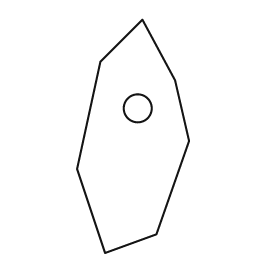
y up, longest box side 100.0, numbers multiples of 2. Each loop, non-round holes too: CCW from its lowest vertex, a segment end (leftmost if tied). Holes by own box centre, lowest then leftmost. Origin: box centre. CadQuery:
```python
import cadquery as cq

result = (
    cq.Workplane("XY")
    .moveTo(-12.0, -50.0)
    .lineTo(10.0, -42.0)
    .lineTo(24.0, -2.0)
    .lineTo(18.0, 24.0)
    .lineTo(4.0, 50.0)
    .lineTo(-14.0, 32.0)
    .lineTo(-24.0, -14.0)
    .close()
    .moveTo(2.0, 12.0)
    .circle(6.0)
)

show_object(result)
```